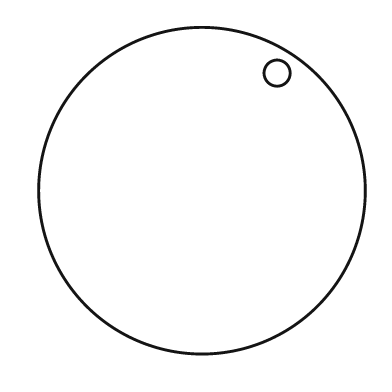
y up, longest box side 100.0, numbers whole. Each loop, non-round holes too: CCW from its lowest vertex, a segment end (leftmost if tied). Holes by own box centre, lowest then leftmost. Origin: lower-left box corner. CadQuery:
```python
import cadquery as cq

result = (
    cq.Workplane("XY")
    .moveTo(50.0, 50.0)
    .circle(50.0)
    .moveTo(73.0, 86.0)
    .circle(4.0)
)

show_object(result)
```